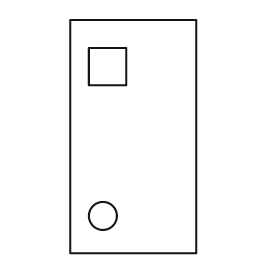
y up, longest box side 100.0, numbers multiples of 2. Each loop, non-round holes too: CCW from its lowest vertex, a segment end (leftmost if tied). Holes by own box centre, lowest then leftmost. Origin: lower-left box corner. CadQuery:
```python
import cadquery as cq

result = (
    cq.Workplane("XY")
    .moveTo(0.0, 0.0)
    .lineTo(54.0, 0.0)
    .lineTo(54.0, 100.0)
    .lineTo(0.0, 100.0)
    .close()
    .moveTo(14.0, 16.0)
    .circle(6.0)
    .moveTo(8.0, 72.0)
    .lineTo(24.0, 72.0)
    .lineTo(24.0, 88.0)
    .lineTo(8.0, 88.0)
    .close()
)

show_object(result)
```